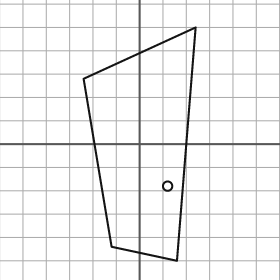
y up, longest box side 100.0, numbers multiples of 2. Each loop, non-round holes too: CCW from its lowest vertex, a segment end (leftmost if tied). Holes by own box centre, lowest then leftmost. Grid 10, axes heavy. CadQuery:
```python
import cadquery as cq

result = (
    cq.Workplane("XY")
    .moveTo(16.0, -50.0)
    .lineTo(24.0, 50.0)
    .lineTo(-24.0, 28.0)
    .lineTo(-12.0, -44.0)
    .close()
    .moveTo(12.0, -18.0)
    .circle(2.0)
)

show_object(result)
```